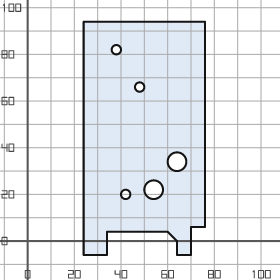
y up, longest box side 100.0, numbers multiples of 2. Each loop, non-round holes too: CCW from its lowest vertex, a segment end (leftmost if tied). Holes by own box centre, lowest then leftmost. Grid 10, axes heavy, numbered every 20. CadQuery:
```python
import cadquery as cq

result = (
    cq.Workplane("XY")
    .moveTo(24.0, -6.0)
    .lineTo(34.0, -6.0)
    .lineTo(34.0, 4.0)
    .lineTo(60.0, 4.0)
    .lineTo(64.0, 0.0)
    .lineTo(64.0, -6.0)
    .lineTo(70.0, -6.0)
    .lineTo(70.0, 6.0)
    .lineTo(76.0, 6.0)
    .lineTo(76.0, 94.0)
    .lineTo(24.0, 94.0)
    .close()
    .moveTo(42.0, 20.0)
    .circle(2.0)
    .moveTo(54.0, 22.0)
    .circle(4.0)
    .moveTo(64.0, 34.0)
    .circle(4.0)
    .moveTo(48.0, 66.0)
    .circle(2.0)
    .moveTo(38.0, 82.0)
    .circle(2.0)
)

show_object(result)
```